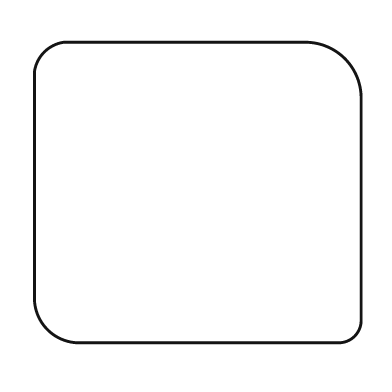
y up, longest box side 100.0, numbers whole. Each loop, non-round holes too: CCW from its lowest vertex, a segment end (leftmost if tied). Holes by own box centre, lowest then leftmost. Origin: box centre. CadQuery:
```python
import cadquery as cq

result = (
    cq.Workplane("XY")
    .moveTo(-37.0, -46.0)
    .lineTo(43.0, -46.0)
    .threePointArc((48.0, -44.0), (50.0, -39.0))
    .lineTo(50.0, 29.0)
    .threePointArc((45.0, 41.0), (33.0, 46.0))
    .lineTo(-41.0, 46.0)
    .threePointArc((-47.0, 43.0), (-50.0, 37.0))
    .lineTo(-50.0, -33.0)
    .threePointArc((-46.0, -42.0), (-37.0, -46.0))
    .close()
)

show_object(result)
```